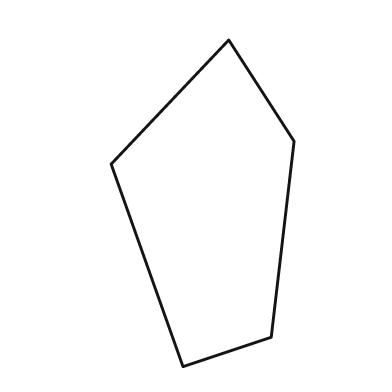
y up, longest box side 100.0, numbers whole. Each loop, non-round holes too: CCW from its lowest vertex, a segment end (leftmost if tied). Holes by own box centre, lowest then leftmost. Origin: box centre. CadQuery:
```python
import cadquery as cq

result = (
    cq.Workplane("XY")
    .moveTo(-6.0, -50.0)
    .lineTo(21.0, -41.0)
    .lineTo(28.0, 19.0)
    .lineTo(8.0, 50.0)
    .lineTo(-28.0, 12.0)
    .close()
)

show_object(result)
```